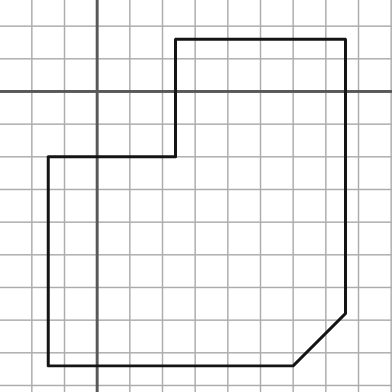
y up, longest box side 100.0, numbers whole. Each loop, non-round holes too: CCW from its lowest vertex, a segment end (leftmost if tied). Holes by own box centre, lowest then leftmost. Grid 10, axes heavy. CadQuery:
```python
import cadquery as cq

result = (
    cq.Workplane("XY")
    .moveTo(-15.0, -84.0)
    .lineTo(60.0, -84.0)
    .lineTo(76.0, -68.0)
    .lineTo(76.0, 16.0)
    .lineTo(24.0, 16.0)
    .lineTo(24.0, -20.0)
    .lineTo(-15.0, -20.0)
    .close()
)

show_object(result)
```